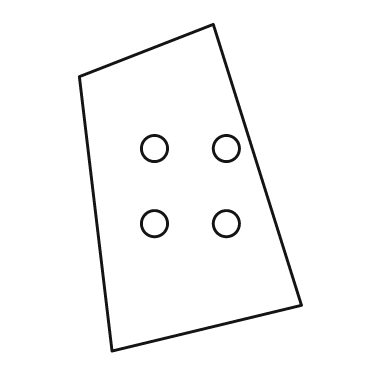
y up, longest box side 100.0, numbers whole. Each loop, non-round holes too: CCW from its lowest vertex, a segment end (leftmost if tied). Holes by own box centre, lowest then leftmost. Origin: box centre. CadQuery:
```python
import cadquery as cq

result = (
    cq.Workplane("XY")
    .moveTo(-24.0, -50.0)
    .lineTo(34.0, -36.0)
    .lineTo(7.0, 50.0)
    .lineTo(-34.0, 34.0)
    .close()
    .moveTo(-11.0, -11.0)
    .circle(4.0)
    .moveTo(11.0, -11.0)
    .circle(4.0)
    .moveTo(-11.0, 12.0)
    .circle(4.0)
    .moveTo(11.0, 12.0)
    .circle(4.0)
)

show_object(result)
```